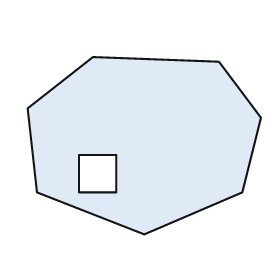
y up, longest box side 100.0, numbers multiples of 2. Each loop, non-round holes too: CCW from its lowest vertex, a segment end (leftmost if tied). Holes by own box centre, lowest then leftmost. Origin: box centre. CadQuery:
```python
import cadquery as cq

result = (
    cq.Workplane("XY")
    .moveTo(0.0, -38.0)
    .lineTo(42.0, -20.0)
    .lineTo(50.0, 12.0)
    .lineTo(32.0, 36.0)
    .lineTo(-22.0, 38.0)
    .lineTo(-50.0, 16.0)
    .lineTo(-46.0, -20.0)
    .close()
    .moveTo(-28.0, -20.0)
    .lineTo(-12.0, -20.0)
    .lineTo(-12.0, -4.0)
    .lineTo(-28.0, -4.0)
    .close()
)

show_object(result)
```